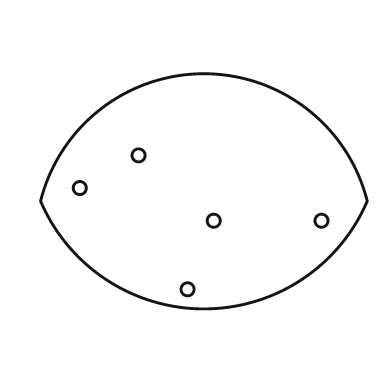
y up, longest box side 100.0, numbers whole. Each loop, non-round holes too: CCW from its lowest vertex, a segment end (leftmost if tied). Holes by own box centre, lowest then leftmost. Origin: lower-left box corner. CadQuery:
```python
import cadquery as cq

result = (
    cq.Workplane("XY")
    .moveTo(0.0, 33.0)
    .threePointArc((50.0, 0.0), (100.0, 33.0))
    .threePointArc((50.0, 72.0), (0.0, 33.0))
    .close()
    .moveTo(45.0, 6.0)
    .circle(2.0)
    .moveTo(53.0, 27.0)
    .circle(2.0)
    .moveTo(86.0, 27.0)
    .circle(2.0)
    .moveTo(12.0, 37.0)
    .circle(2.0)
    .moveTo(30.0, 47.0)
    .circle(2.0)
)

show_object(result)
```